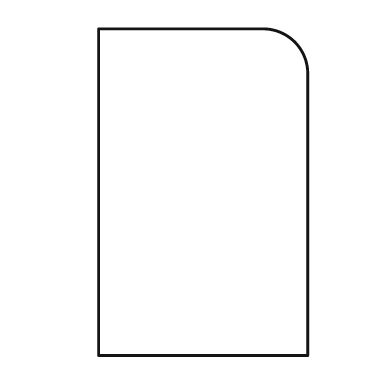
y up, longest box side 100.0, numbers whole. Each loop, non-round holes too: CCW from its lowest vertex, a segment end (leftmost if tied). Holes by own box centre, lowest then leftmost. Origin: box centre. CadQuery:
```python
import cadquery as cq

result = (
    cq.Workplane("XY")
    .moveTo(-32.0, -50.0)
    .lineTo(32.0, -50.0)
    .lineTo(32.0, 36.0)
    .threePointArc((28.0, 46.0), (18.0, 50.0))
    .lineTo(-32.0, 50.0)
    .close()
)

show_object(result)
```